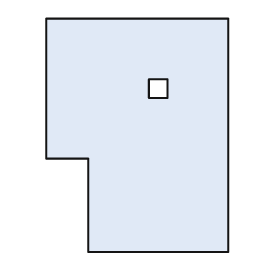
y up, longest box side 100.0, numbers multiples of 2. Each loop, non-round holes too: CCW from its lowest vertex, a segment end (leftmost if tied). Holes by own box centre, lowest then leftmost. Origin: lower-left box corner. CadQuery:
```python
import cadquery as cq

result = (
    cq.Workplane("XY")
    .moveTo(18.0, 0.0)
    .lineTo(78.0, 0.0)
    .lineTo(78.0, 100.0)
    .lineTo(0.0, 100.0)
    .lineTo(0.0, 40.0)
    .lineTo(18.0, 40.0)
    .close()
    .moveTo(44.0, 66.0)
    .lineTo(52.0, 66.0)
    .lineTo(52.0, 74.0)
    .lineTo(44.0, 74.0)
    .close()
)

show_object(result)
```